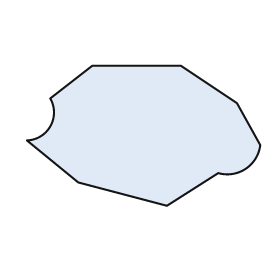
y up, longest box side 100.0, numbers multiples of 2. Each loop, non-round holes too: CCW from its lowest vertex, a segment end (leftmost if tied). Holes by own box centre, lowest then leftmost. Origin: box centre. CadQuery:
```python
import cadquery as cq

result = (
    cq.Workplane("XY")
    .moveTo(10.0, -30.0)
    .lineTo(32.0, -16.0)
    .threePointArc((44.0, -14.0), (50.0, -4.0))
    .lineTo(40.0, 14.0)
    .lineTo(16.0, 30.0)
    .lineTo(-22.0, 30.0)
    .lineTo(-40.0, 16.0)
    .threePointArc((-40.0, 4.0), (-50.0, -2.0))
    .lineTo(-28.0, -20.0)
    .close()
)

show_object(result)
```